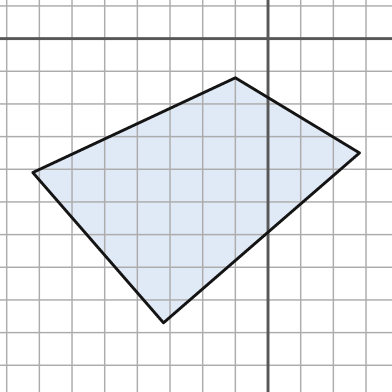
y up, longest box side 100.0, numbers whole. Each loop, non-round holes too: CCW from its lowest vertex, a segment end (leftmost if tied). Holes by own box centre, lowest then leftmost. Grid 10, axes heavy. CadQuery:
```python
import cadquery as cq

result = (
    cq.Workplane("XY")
    .moveTo(-32.0, -87.0)
    .lineTo(28.0, -35.0)
    .lineTo(-10.0, -12.0)
    .lineTo(-72.0, -41.0)
    .close()
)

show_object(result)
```